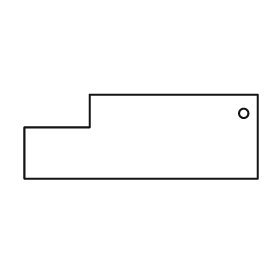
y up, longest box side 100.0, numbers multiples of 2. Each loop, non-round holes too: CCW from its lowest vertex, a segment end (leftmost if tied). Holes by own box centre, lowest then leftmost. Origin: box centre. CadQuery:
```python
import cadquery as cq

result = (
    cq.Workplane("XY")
    .moveTo(-50.0, -18.0)
    .lineTo(50.0, -18.0)
    .lineTo(50.0, 18.0)
    .lineTo(-22.0, 18.0)
    .lineTo(-22.0, 4.0)
    .lineTo(-50.0, 4.0)
    .close()
    .moveTo(44.0, 10.0)
    .circle(2.0)
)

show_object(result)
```